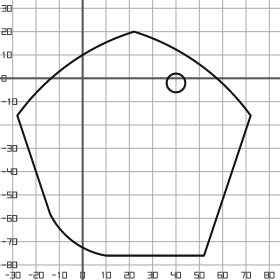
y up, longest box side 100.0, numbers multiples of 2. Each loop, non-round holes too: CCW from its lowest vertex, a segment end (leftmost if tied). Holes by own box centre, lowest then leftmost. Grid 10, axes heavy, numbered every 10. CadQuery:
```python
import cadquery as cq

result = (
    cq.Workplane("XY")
    .moveTo(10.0, -76.0)
    .lineTo(52.0, -76.0)
    .lineTo(72.0, -16.0)
    .threePointArc((50.0, 6.0), (22.0, 20.0))
    .threePointArc((-6.0, 6.0), (-28.0, -16.0))
    .lineTo(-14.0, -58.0)
    .threePointArc((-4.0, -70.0), (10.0, -76.0))
    .close()
    .moveTo(40.0, -2.0)
    .circle(4.0)
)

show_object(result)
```